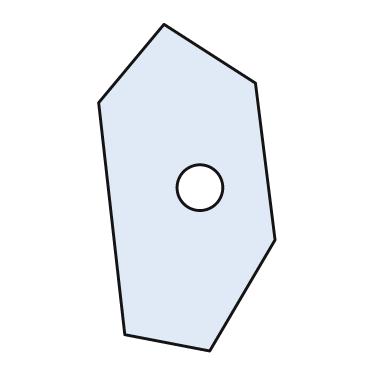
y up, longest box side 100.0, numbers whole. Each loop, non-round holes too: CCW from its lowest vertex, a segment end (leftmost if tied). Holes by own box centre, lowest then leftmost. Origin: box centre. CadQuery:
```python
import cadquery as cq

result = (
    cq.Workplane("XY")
    .moveTo(7.0, -50.0)
    .lineTo(27.0, -16.0)
    .lineTo(21.0, 32.0)
    .lineTo(-7.0, 50.0)
    .lineTo(-27.0, 26.0)
    .lineTo(-19.0, -45.0)
    .close()
    .moveTo(4.0, 0.0)
    .circle(7.0)
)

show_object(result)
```